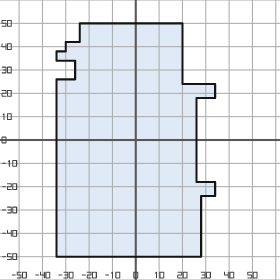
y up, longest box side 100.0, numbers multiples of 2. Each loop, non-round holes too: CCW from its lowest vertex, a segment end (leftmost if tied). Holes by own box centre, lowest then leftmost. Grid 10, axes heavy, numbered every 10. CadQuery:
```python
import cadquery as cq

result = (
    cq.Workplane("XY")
    .moveTo(-34.0, -50.0)
    .lineTo(28.0, -50.0)
    .lineTo(28.0, -24.0)
    .lineTo(34.0, -24.0)
    .lineTo(34.0, -18.0)
    .lineTo(26.0, -18.0)
    .lineTo(26.0, 18.0)
    .lineTo(34.0, 18.0)
    .lineTo(34.0, 24.0)
    .lineTo(20.0, 24.0)
    .lineTo(20.0, 50.0)
    .lineTo(-24.0, 50.0)
    .lineTo(-24.0, 42.0)
    .lineTo(-30.0, 42.0)
    .lineTo(-30.0, 38.0)
    .lineTo(-34.0, 38.0)
    .lineTo(-34.0, 34.0)
    .lineTo(-26.0, 34.0)
    .lineTo(-26.0, 26.0)
    .lineTo(-34.0, 26.0)
    .close()
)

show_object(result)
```